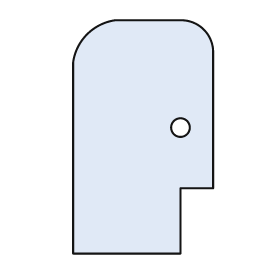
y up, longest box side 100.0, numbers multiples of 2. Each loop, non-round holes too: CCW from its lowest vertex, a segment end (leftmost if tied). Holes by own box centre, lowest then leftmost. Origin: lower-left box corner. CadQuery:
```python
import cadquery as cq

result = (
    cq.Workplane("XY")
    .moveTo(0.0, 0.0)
    .lineTo(46.0, 0.0)
    .lineTo(46.0, 28.0)
    .lineTo(60.0, 28.0)
    .lineTo(60.0, 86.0)
    .threePointArc((56.0, 96.0), (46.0, 100.0))
    .lineTo(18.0, 100.0)
    .threePointArc((6.0, 94.0), (0.0, 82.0))
    .close()
    .moveTo(46.0, 54.0)
    .circle(4.0)
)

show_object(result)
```